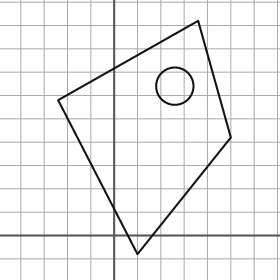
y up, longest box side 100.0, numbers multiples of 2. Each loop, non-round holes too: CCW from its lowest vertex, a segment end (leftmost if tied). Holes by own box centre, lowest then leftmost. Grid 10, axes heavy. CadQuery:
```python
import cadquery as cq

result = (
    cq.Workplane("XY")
    .moveTo(10.0, -8.0)
    .lineTo(50.0, 42.0)
    .lineTo(36.0, 92.0)
    .lineTo(-24.0, 58.0)
    .close()
    .moveTo(26.0, 64.0)
    .circle(8.0)
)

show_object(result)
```